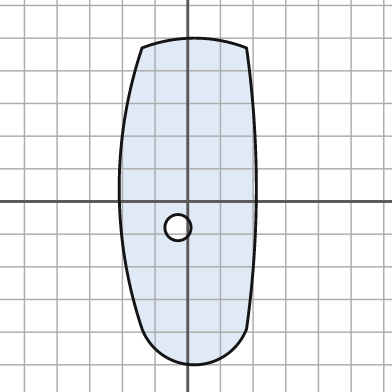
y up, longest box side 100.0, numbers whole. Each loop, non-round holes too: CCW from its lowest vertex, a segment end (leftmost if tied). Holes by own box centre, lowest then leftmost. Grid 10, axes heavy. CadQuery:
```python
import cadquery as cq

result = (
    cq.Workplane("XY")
    .moveTo(-14.0, -39.0)
    .threePointArc((2.0, -50.0), (18.0, -39.0))
    .threePointArc((21.0, 4.0), (18.0, 47.0))
    .threePointArc((2.0, 50.0), (-14.0, 47.0))
    .threePointArc((-21.0, 4.0), (-14.0, -39.0))
    .close()
    .moveTo(-3.0, -8.0)
    .circle(4.0)
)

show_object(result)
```